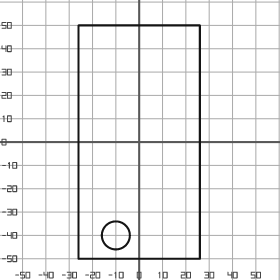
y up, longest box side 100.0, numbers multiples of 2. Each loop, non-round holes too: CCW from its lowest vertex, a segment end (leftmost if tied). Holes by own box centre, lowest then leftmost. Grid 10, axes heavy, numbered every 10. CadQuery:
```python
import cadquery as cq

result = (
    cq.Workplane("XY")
    .moveTo(-26.0, -50.0)
    .lineTo(26.0, -50.0)
    .lineTo(26.0, 50.0)
    .lineTo(-26.0, 50.0)
    .close()
    .moveTo(-10.0, -40.0)
    .circle(6.0)
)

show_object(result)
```